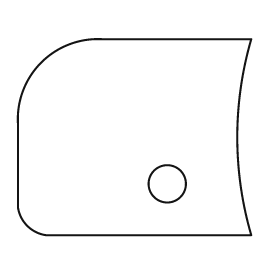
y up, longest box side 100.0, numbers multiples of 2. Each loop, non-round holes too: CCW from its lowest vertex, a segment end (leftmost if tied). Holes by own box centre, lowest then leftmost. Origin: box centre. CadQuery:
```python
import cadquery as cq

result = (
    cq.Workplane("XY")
    .moveTo(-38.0, -42.0)
    .lineTo(50.0, -42.0)
    .threePointArc((44.0, 0.0), (50.0, 42.0))
    .lineTo(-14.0, 42.0)
    .threePointArc((-40.0, 32.0), (-50.0, 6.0))
    .lineTo(-50.0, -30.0)
    .threePointArc((-46.0, -38.0), (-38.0, -42.0))
    .close()
    .moveTo(14.0, -20.0)
    .circle(8.0)
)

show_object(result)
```